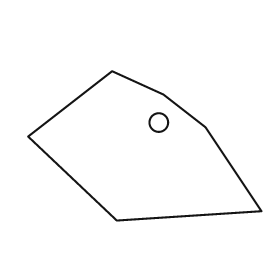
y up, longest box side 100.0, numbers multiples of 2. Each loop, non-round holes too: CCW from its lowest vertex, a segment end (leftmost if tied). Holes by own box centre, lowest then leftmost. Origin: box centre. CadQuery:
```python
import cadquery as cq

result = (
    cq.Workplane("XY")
    .moveTo(-12.0, -32.0)
    .lineTo(50.0, -28.0)
    .lineTo(26.0, 8.0)
    .lineTo(8.0, 22.0)
    .lineTo(-14.0, 32.0)
    .lineTo(-50.0, 4.0)
    .close()
    .moveTo(6.0, 10.0)
    .circle(4.0)
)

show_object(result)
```